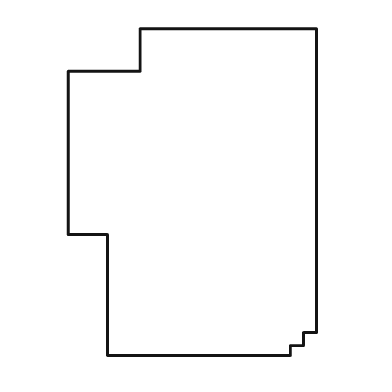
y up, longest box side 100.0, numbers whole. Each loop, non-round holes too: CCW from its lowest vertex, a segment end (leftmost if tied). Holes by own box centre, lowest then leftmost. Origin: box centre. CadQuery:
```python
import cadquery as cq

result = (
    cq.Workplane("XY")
    .moveTo(-26.0, -50.0)
    .lineTo(30.0, -50.0)
    .lineTo(30.0, -47.0)
    .lineTo(34.0, -47.0)
    .lineTo(34.0, -43.0)
    .lineTo(38.0, -43.0)
    .lineTo(38.0, 50.0)
    .lineTo(-16.0, 50.0)
    .lineTo(-16.0, 37.0)
    .lineTo(-38.0, 37.0)
    .lineTo(-38.0, -13.0)
    .lineTo(-26.0, -13.0)
    .close()
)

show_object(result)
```